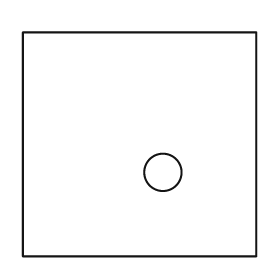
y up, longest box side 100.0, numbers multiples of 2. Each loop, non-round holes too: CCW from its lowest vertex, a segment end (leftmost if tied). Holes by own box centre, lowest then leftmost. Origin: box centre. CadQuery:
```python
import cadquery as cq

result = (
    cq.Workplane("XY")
    .moveTo(-50.0, -48.0)
    .lineTo(50.0, -48.0)
    .lineTo(50.0, 48.0)
    .lineTo(-50.0, 48.0)
    .close()
    .moveTo(10.0, -12.0)
    .circle(8.0)
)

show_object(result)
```